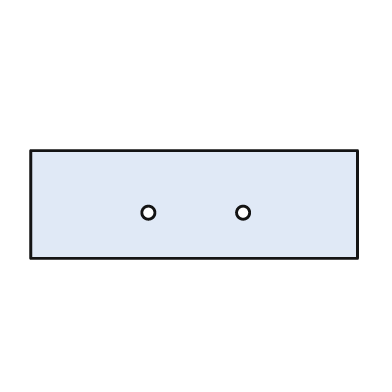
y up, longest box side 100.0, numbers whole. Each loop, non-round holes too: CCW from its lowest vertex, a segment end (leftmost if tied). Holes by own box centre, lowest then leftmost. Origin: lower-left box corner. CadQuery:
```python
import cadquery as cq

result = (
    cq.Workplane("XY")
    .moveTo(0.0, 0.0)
    .lineTo(100.0, 0.0)
    .lineTo(100.0, 33.0)
    .lineTo(0.0, 33.0)
    .close()
    .moveTo(36.0, 14.0)
    .circle(2.0)
    .moveTo(65.0, 14.0)
    .circle(2.0)
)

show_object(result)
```